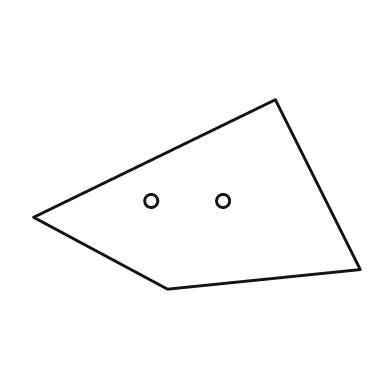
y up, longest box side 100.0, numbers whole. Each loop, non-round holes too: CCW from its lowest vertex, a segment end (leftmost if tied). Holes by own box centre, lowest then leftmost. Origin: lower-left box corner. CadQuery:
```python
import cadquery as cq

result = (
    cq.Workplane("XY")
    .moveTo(41.0, 0.0)
    .lineTo(100.0, 6.0)
    .lineTo(74.0, 58.0)
    .lineTo(0.0, 22.0)
    .close()
    .moveTo(36.0, 27.0)
    .circle(2.0)
    .moveTo(58.0, 27.0)
    .circle(2.0)
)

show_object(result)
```